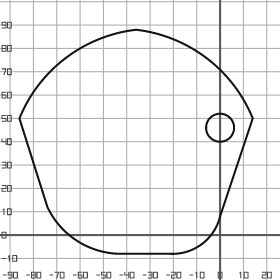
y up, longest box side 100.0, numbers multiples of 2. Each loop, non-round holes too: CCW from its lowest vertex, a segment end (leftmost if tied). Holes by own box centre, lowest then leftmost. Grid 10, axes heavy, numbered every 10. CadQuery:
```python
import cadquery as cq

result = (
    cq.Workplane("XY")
    .moveTo(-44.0, -8.0)
    .lineTo(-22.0, -8.0)
    .threePointArc((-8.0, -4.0), (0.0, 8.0))
    .lineTo(14.0, 50.0)
    .threePointArc((-6.0, 76.0), (-36.0, 88.0))
    .threePointArc((-66.0, 76.0), (-86.0, 50.0))
    .lineTo(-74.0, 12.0)
    .threePointArc((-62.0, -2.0), (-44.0, -8.0))
    .close()
    .moveTo(0.0, 46.0)
    .circle(6.0)
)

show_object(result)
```